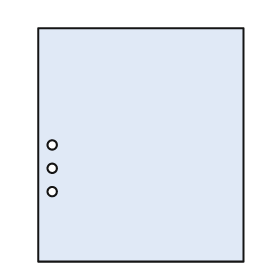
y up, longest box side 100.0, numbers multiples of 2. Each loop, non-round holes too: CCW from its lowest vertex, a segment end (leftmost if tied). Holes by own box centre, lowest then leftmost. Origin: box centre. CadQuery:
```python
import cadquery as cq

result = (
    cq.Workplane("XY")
    .moveTo(-44.0, -50.0)
    .lineTo(44.0, -50.0)
    .lineTo(44.0, 50.0)
    .lineTo(-44.0, 50.0)
    .close()
    .moveTo(-38.0, -20.0)
    .circle(2.0)
    .moveTo(-38.0, -10.0)
    .circle(2.0)
    .moveTo(-38.0, 0.0)
    .circle(2.0)
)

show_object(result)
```